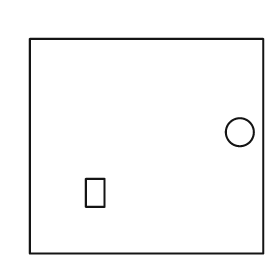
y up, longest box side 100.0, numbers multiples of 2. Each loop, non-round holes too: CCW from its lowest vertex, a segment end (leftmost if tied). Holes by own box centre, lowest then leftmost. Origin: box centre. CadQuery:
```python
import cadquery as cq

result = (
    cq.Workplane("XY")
    .moveTo(-50.0, -46.0)
    .lineTo(50.0, -46.0)
    .lineTo(50.0, 46.0)
    .lineTo(-50.0, 46.0)
    .close()
    .moveTo(-26.0, -26.0)
    .lineTo(-18.0, -26.0)
    .lineTo(-18.0, -14.0)
    .lineTo(-26.0, -14.0)
    .close()
    .moveTo(40.0, 6.0)
    .circle(6.0)
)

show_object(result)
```